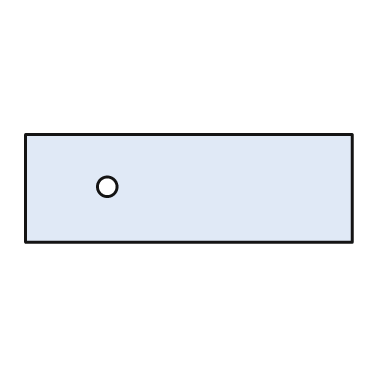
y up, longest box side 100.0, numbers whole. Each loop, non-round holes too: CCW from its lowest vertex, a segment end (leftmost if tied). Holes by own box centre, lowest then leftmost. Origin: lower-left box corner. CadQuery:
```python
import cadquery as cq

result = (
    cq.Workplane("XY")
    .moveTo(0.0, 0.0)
    .lineTo(100.0, 0.0)
    .lineTo(100.0, 33.0)
    .lineTo(0.0, 33.0)
    .close()
    .moveTo(25.0, 17.0)
    .circle(3.0)
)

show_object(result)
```